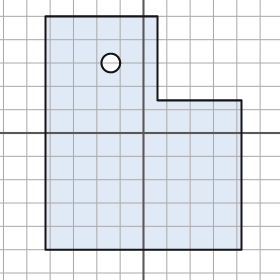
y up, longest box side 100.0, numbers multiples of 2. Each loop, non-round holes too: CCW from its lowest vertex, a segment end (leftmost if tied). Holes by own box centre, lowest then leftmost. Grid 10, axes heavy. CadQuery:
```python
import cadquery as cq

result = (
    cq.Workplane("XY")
    .moveTo(-42.0, -50.0)
    .lineTo(42.0, -50.0)
    .lineTo(42.0, 14.0)
    .lineTo(6.0, 14.0)
    .lineTo(6.0, 50.0)
    .lineTo(-42.0, 50.0)
    .close()
    .moveTo(-14.0, 30.0)
    .circle(4.0)
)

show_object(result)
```